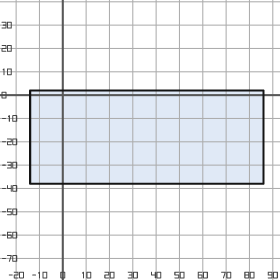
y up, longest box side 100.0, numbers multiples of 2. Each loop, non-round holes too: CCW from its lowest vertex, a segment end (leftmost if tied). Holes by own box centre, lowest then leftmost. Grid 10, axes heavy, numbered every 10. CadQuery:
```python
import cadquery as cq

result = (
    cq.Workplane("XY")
    .moveTo(-14.0, -38.0)
    .lineTo(86.0, -38.0)
    .lineTo(86.0, 2.0)
    .lineTo(-14.0, 2.0)
    .close()
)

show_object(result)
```